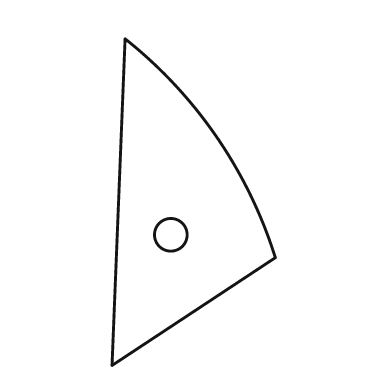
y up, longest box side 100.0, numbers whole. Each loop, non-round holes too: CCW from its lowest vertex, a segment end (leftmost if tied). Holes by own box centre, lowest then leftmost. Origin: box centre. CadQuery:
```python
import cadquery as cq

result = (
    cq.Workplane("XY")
    .moveTo(-25.0, -50.0)
    .lineTo(25.0, -17.0)
    .threePointArc((7.0, 20.0), (-21.0, 50.0))
    .close()
    .moveTo(-7.0, -10.0)
    .circle(5.0)
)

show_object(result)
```